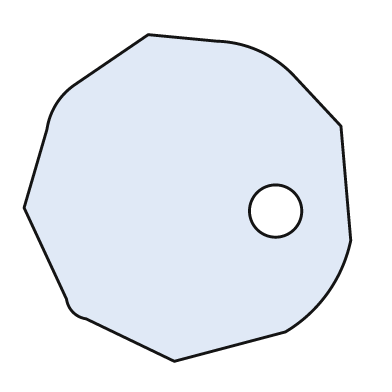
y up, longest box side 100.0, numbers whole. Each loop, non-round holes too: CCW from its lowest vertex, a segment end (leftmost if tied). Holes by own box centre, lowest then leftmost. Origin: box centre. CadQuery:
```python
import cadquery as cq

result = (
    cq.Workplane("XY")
    .moveTo(-4.0, -50.0)
    .lineTo(30.0, -41.0)
    .threePointArc((43.0, -29.0), (50.0, -13.0))
    .lineTo(47.0, 22.0)
    .lineTo(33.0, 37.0)
    .threePointArc((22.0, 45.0), (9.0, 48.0))
    .lineTo(-12.0, 50.0)
    .lineTo(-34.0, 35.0)
    .threePointArc((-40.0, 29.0), (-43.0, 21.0))
    .lineTo(-50.0, -3.0)
    .lineTo(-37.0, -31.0)
    .threePointArc((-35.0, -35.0), (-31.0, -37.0))
    .close()
    .moveTo(27.0, -4.0)
    .circle(8.0)
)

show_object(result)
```